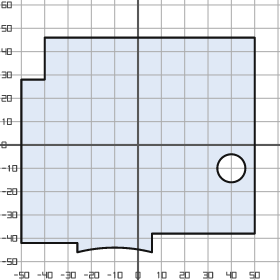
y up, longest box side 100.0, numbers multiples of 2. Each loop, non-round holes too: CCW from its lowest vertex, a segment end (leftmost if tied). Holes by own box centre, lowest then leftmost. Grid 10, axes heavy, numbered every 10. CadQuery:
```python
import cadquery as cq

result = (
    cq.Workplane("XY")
    .moveTo(-26.0, -46.0)
    .threePointArc((-10.0, -44.0), (6.0, -46.0))
    .lineTo(6.0, -38.0)
    .lineTo(50.0, -38.0)
    .lineTo(50.0, 46.0)
    .lineTo(-40.0, 46.0)
    .lineTo(-40.0, 28.0)
    .lineTo(-50.0, 28.0)
    .lineTo(-50.0, -42.0)
    .lineTo(-26.0, -42.0)
    .close()
    .moveTo(40.0, -10.0)
    .circle(6.0)
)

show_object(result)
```